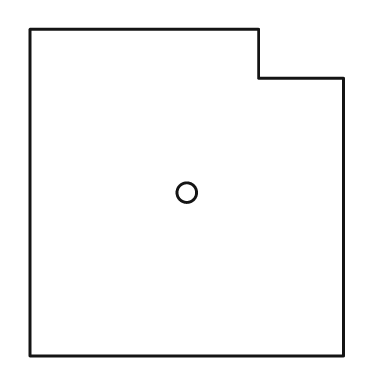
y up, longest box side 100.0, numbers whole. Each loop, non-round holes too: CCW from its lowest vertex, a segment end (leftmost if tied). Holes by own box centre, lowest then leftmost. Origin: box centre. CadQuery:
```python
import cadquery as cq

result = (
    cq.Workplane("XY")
    .moveTo(-48.0, -50.0)
    .lineTo(48.0, -50.0)
    .lineTo(48.0, 35.0)
    .lineTo(22.0, 35.0)
    .lineTo(22.0, 50.0)
    .lineTo(-48.0, 50.0)
    .close()
    .moveTo(0.0, 0.0)
    .circle(3.0)
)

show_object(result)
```